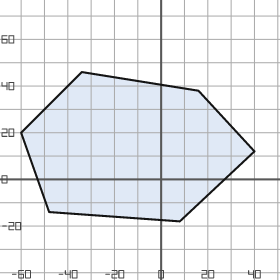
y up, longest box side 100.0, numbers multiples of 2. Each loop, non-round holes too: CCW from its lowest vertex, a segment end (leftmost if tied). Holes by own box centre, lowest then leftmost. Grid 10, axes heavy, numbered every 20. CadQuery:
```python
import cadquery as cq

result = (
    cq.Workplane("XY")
    .moveTo(8.0, -18.0)
    .lineTo(40.0, 12.0)
    .lineTo(16.0, 38.0)
    .lineTo(-34.0, 46.0)
    .lineTo(-60.0, 20.0)
    .lineTo(-48.0, -14.0)
    .close()
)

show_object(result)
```